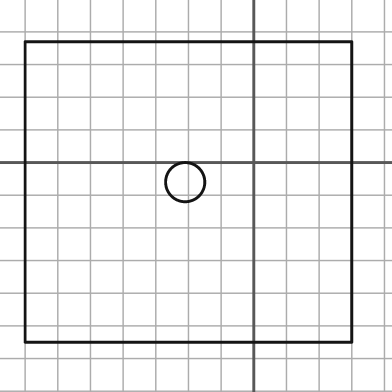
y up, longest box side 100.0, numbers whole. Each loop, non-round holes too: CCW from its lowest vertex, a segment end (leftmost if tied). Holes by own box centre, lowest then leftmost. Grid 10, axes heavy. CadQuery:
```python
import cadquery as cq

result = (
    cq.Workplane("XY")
    .moveTo(-70.0, -55.0)
    .lineTo(30.0, -55.0)
    .lineTo(30.0, 37.0)
    .lineTo(-70.0, 37.0)
    .close()
    .moveTo(-21.0, -6.0)
    .circle(6.0)
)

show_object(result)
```